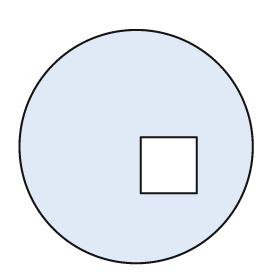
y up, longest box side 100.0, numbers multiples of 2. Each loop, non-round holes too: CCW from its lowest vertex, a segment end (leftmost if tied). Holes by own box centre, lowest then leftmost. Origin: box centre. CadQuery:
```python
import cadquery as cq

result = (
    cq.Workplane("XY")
    .moveTo(0.0, 0.0)
    .circle(50.0)
    .moveTo(2.0, -20.0)
    .lineTo(26.0, -20.0)
    .lineTo(26.0, 4.0)
    .lineTo(2.0, 4.0)
    .close()
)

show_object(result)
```